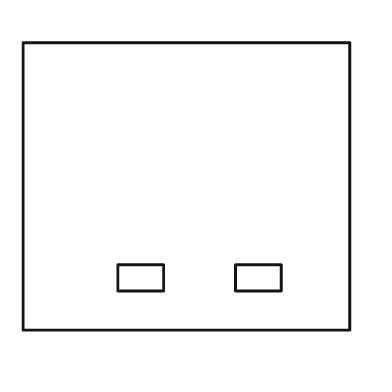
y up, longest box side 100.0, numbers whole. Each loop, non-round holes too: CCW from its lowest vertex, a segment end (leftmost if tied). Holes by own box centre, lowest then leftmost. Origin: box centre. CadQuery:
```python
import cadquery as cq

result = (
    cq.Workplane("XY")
    .moveTo(-50.0, -44.0)
    .lineTo(50.0, -44.0)
    .lineTo(50.0, 44.0)
    .lineTo(-50.0, 44.0)
    .close()
    .moveTo(-21.0, -32.0)
    .lineTo(-7.0, -32.0)
    .lineTo(-7.0, -24.0)
    .lineTo(-21.0, -24.0)
    .close()
    .moveTo(15.0, -32.0)
    .lineTo(29.0, -32.0)
    .lineTo(29.0, -24.0)
    .lineTo(15.0, -24.0)
    .close()
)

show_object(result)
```